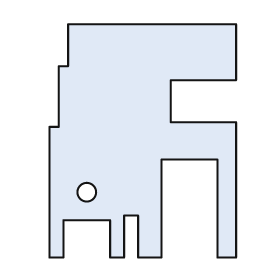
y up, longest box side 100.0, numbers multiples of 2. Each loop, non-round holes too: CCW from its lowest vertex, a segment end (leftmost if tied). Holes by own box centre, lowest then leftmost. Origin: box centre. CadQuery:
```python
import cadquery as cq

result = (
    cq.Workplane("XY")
    .moveTo(-40.0, -50.0)
    .lineTo(-34.0, -50.0)
    .lineTo(-34.0, -34.0)
    .lineTo(-14.0, -34.0)
    .lineTo(-14.0, -50.0)
    .lineTo(-8.0, -50.0)
    .lineTo(-8.0, -32.0)
    .lineTo(-2.0, -32.0)
    .lineTo(-2.0, -50.0)
    .lineTo(8.0, -50.0)
    .lineTo(8.0, -8.0)
    .lineTo(32.0, -8.0)
    .lineTo(32.0, -50.0)
    .lineTo(40.0, -50.0)
    .lineTo(40.0, 8.0)
    .lineTo(12.0, 8.0)
    .lineTo(12.0, 26.0)
    .lineTo(40.0, 26.0)
    .lineTo(40.0, 50.0)
    .lineTo(-32.0, 50.0)
    .lineTo(-32.0, 32.0)
    .lineTo(-36.0, 32.0)
    .lineTo(-36.0, 6.0)
    .lineTo(-40.0, 6.0)
    .close()
    .moveTo(-24.0, -22.0)
    .circle(4.0)
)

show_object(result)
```